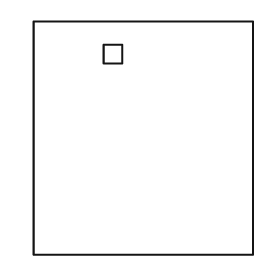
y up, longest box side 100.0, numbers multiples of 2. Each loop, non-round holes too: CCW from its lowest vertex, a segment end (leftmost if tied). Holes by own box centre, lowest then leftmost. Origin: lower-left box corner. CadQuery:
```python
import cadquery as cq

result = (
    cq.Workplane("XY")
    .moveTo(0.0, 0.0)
    .lineTo(94.0, 0.0)
    .lineTo(94.0, 100.0)
    .lineTo(0.0, 100.0)
    .close()
    .moveTo(30.0, 82.0)
    .lineTo(38.0, 82.0)
    .lineTo(38.0, 90.0)
    .lineTo(30.0, 90.0)
    .close()
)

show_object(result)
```